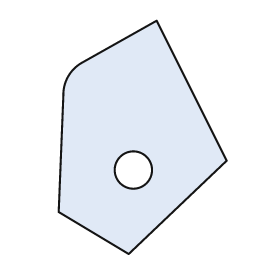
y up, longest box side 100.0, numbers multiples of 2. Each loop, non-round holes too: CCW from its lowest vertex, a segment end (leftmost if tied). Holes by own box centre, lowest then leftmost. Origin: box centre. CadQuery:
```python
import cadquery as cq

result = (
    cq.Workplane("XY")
    .moveTo(-6.0, -50.0)
    .lineTo(36.0, -10.0)
    .lineTo(6.0, 50.0)
    .lineTo(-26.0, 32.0)
    .threePointArc((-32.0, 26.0), (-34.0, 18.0))
    .lineTo(-36.0, -32.0)
    .close()
    .moveTo(-4.0, -14.0)
    .circle(8.0)
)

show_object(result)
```